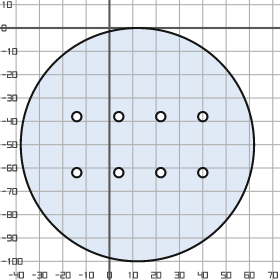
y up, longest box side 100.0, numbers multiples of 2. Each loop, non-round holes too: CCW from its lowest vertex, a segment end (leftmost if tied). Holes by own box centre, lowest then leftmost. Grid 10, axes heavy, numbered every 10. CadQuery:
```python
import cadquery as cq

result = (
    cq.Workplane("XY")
    .moveTo(12.0, -50.0)
    .circle(50.0)
    .moveTo(-14.0, -62.0)
    .circle(2.0)
    .moveTo(4.0, -62.0)
    .circle(2.0)
    .moveTo(22.0, -62.0)
    .circle(2.0)
    .moveTo(40.0, -62.0)
    .circle(2.0)
    .moveTo(-14.0, -38.0)
    .circle(2.0)
    .moveTo(4.0, -38.0)
    .circle(2.0)
    .moveTo(22.0, -38.0)
    .circle(2.0)
    .moveTo(40.0, -38.0)
    .circle(2.0)
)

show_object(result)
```